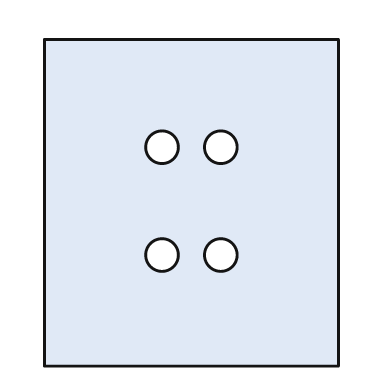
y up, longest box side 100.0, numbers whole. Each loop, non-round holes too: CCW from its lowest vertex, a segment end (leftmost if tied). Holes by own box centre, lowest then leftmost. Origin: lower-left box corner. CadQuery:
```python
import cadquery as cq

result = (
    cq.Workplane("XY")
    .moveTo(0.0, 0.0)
    .lineTo(90.0, 0.0)
    .lineTo(90.0, 100.0)
    .lineTo(0.0, 100.0)
    .close()
    .moveTo(36.0, 34.0)
    .circle(5.0)
    .moveTo(54.0, 34.0)
    .circle(5.0)
    .moveTo(36.0, 67.0)
    .circle(5.0)
    .moveTo(54.0, 67.0)
    .circle(5.0)
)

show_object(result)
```